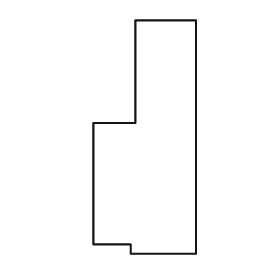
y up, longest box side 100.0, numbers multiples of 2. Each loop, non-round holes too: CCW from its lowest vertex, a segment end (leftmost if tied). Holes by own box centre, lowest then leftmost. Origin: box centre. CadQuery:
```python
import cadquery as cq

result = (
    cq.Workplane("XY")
    .moveTo(-6.0, -50.0)
    .lineTo(22.0, -50.0)
    .lineTo(22.0, 50.0)
    .lineTo(-4.0, 50.0)
    .lineTo(-4.0, 6.0)
    .lineTo(-22.0, 6.0)
    .lineTo(-22.0, -46.0)
    .lineTo(-6.0, -46.0)
    .close()
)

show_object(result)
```